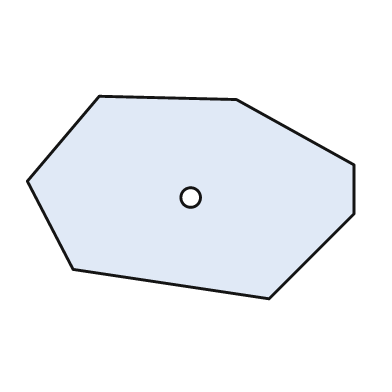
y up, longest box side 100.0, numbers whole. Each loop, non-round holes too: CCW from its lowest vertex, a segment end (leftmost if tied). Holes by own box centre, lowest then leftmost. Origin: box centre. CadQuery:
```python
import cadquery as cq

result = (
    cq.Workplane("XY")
    .moveTo(24.0, -31.0)
    .lineTo(50.0, -5.0)
    .lineTo(50.0, 10.0)
    .lineTo(14.0, 30.0)
    .lineTo(-28.0, 31.0)
    .lineTo(-50.0, 5.0)
    .lineTo(-36.0, -22.0)
    .close()
    .moveTo(0.0, 0.0)
    .circle(3.0)
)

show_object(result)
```